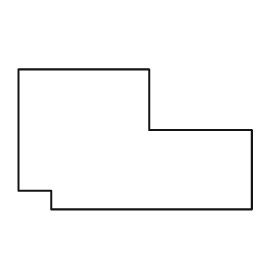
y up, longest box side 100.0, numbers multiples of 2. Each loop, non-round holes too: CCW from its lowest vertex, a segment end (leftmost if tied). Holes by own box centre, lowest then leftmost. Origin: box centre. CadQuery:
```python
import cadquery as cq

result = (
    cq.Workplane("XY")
    .moveTo(-36.0, -30.0)
    .lineTo(50.0, -30.0)
    .lineTo(50.0, 4.0)
    .lineTo(6.0, 4.0)
    .lineTo(6.0, 30.0)
    .lineTo(-50.0, 30.0)
    .lineTo(-50.0, -22.0)
    .lineTo(-36.0, -22.0)
    .close()
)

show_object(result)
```